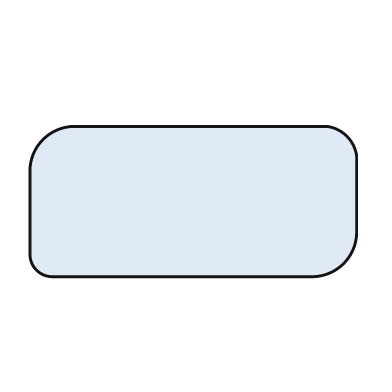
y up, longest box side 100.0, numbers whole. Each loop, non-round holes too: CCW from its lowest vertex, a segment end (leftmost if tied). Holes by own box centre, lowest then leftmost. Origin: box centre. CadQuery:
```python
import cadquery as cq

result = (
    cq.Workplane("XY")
    .moveTo(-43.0, -23.0)
    .lineTo(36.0, -23.0)
    .threePointArc((46.0, -19.0), (50.0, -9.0))
    .lineTo(50.0, 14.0)
    .threePointArc((47.0, 20.0), (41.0, 23.0))
    .lineTo(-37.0, 23.0)
    .threePointArc((-46.0, 19.0), (-50.0, 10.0))
    .lineTo(-50.0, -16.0)
    .threePointArc((-48.0, -21.0), (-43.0, -23.0))
    .close()
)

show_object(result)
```